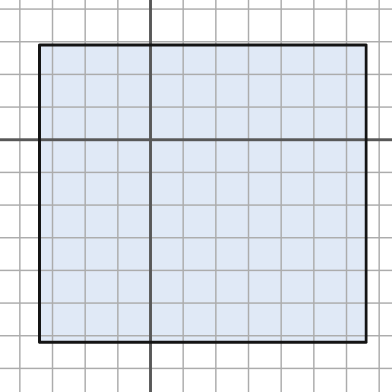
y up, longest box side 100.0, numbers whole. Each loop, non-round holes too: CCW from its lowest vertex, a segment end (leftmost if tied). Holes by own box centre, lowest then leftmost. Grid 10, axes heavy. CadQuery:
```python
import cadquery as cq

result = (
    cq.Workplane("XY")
    .moveTo(-34.0, -62.0)
    .lineTo(66.0, -62.0)
    .lineTo(66.0, 29.0)
    .lineTo(-34.0, 29.0)
    .close()
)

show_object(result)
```